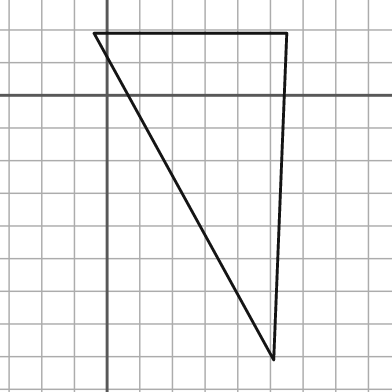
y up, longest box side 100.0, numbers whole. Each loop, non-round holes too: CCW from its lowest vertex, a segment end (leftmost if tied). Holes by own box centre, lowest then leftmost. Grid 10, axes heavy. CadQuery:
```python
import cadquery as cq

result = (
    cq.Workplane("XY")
    .moveTo(51.0, -81.0)
    .lineTo(55.0, 19.0)
    .lineTo(-4.0, 19.0)
    .close()
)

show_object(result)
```